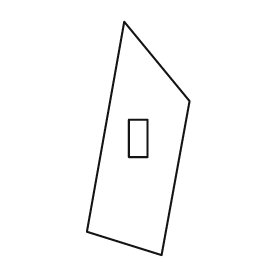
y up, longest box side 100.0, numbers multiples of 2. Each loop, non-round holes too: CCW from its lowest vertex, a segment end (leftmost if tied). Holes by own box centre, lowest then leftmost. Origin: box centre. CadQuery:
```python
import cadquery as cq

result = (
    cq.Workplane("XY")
    .moveTo(10.0, -50.0)
    .lineTo(22.0, 16.0)
    .lineTo(-6.0, 50.0)
    .lineTo(-22.0, -40.0)
    .close()
    .moveTo(-4.0, -8.0)
    .lineTo(4.0, -8.0)
    .lineTo(4.0, 8.0)
    .lineTo(-4.0, 8.0)
    .close()
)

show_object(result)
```